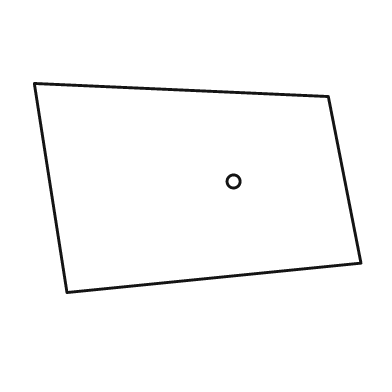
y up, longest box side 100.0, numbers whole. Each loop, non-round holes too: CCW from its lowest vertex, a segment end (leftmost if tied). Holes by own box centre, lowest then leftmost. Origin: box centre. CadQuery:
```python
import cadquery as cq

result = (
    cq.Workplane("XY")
    .moveTo(-40.0, -32.0)
    .lineTo(50.0, -23.0)
    .lineTo(40.0, 28.0)
    .lineTo(-50.0, 32.0)
    .close()
    .moveTo(11.0, 2.0)
    .circle(2.0)
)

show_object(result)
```